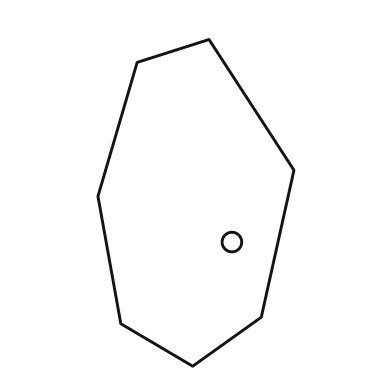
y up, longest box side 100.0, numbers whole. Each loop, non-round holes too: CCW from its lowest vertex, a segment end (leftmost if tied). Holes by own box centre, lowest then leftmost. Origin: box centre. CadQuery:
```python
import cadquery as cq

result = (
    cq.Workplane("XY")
    .moveTo(-1.0, -50.0)
    .lineTo(20.0, -35.0)
    .lineTo(30.0, 10.0)
    .lineTo(4.0, 50.0)
    .lineTo(-18.0, 43.0)
    .lineTo(-30.0, 2.0)
    .lineTo(-23.0, -37.0)
    .close()
    .moveTo(11.0, -12.0)
    .circle(3.0)
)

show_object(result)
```